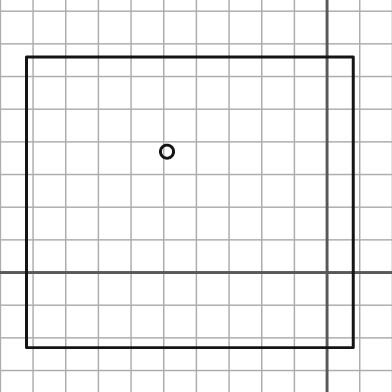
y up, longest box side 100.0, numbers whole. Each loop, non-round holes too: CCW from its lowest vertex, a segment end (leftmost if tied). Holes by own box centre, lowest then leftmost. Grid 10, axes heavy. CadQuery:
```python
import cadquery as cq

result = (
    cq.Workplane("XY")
    .moveTo(-92.0, -23.0)
    .lineTo(8.0, -23.0)
    .lineTo(8.0, 66.0)
    .lineTo(-92.0, 66.0)
    .close()
    .moveTo(-49.0, 37.0)
    .circle(2.0)
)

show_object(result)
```